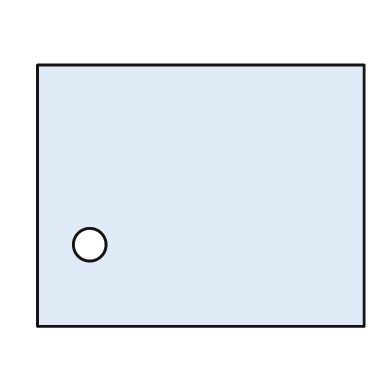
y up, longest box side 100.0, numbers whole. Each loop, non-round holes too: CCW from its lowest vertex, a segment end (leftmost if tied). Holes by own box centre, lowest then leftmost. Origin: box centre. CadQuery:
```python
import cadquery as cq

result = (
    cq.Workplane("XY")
    .moveTo(-50.0, -40.0)
    .lineTo(50.0, -40.0)
    .lineTo(50.0, 40.0)
    .lineTo(-50.0, 40.0)
    .close()
    .moveTo(-34.0, -15.0)
    .circle(5.0)
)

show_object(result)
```